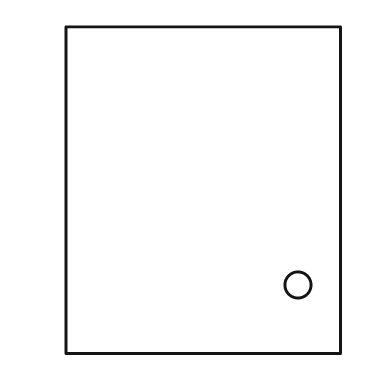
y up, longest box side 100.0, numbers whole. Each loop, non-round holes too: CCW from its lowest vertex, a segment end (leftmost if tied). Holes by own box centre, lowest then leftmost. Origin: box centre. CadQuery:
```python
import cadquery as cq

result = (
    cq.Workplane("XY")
    .moveTo(-42.0, -50.0)
    .lineTo(42.0, -50.0)
    .lineTo(42.0, 50.0)
    .lineTo(-42.0, 50.0)
    .close()
    .moveTo(29.0, -29.0)
    .circle(4.0)
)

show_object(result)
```